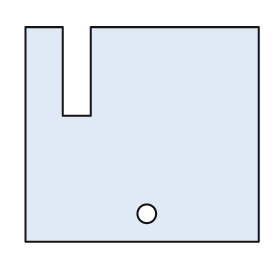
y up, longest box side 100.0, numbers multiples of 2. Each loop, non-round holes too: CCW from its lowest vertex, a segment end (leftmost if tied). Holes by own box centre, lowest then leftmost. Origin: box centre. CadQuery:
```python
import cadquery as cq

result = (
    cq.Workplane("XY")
    .moveTo(-50.0, -46.0)
    .lineTo(50.0, -46.0)
    .lineTo(50.0, 46.0)
    .lineTo(-22.0, 46.0)
    .lineTo(-22.0, 8.0)
    .lineTo(-34.0, 8.0)
    .lineTo(-34.0, 46.0)
    .lineTo(-50.0, 46.0)
    .close()
    .moveTo(2.0, -34.0)
    .circle(4.0)
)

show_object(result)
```